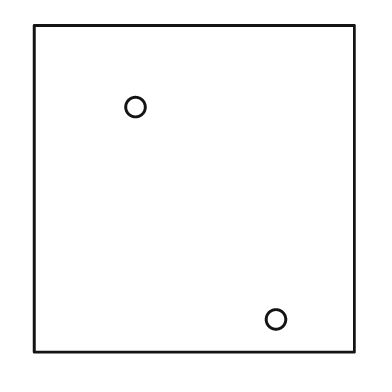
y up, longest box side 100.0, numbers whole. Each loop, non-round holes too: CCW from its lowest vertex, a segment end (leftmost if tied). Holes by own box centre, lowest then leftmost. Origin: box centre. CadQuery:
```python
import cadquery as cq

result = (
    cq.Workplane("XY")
    .moveTo(-49.0, -50.0)
    .lineTo(49.0, -50.0)
    .lineTo(49.0, 50.0)
    .lineTo(-49.0, 50.0)
    .close()
    .moveTo(25.0, -40.0)
    .circle(3.0)
    .moveTo(-18.0, 25.0)
    .circle(3.0)
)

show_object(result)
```